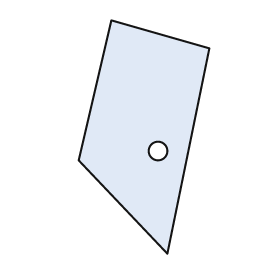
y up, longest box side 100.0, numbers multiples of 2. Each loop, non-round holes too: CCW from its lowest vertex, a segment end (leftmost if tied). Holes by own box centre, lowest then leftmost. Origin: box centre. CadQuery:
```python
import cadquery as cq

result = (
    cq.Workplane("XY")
    .moveTo(10.0, -50.0)
    .lineTo(28.0, 38.0)
    .lineTo(-14.0, 50.0)
    .lineTo(-28.0, -10.0)
    .close()
    .moveTo(6.0, -6.0)
    .circle(4.0)
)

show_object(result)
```